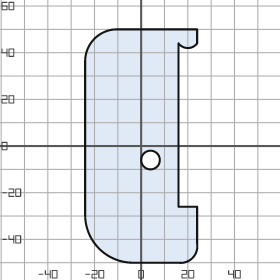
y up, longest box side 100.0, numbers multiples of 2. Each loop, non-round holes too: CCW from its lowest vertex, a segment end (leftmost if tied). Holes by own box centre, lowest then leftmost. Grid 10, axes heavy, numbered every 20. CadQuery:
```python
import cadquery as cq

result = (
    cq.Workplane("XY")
    .moveTo(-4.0, -50.0)
    .lineTo(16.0, -50.0)
    .threePointArc((22.0, -48.0), (24.0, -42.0))
    .lineTo(24.0, -26.0)
    .lineTo(16.0, -26.0)
    .lineTo(16.0, 44.0)
    .threePointArc((20.0, 42.0), (24.0, 44.0))
    .lineTo(24.0, 50.0)
    .lineTo(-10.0, 50.0)
    .threePointArc((-20.0, 46.0), (-24.0, 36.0))
    .lineTo(-24.0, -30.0)
    .threePointArc((-18.0, -44.0), (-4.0, -50.0))
    .close()
    .moveTo(4.0, -6.0)
    .circle(4.0)
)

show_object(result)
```